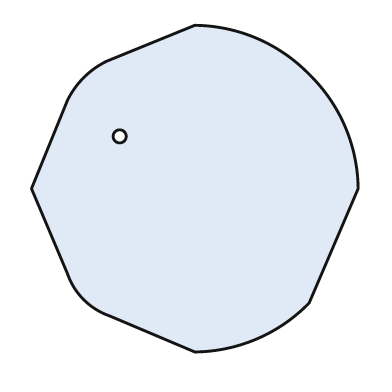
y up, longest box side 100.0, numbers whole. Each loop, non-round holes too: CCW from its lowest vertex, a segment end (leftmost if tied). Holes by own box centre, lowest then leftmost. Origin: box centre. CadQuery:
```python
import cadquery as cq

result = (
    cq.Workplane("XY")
    .moveTo(0.0, -50.0)
    .threePointArc((19.0, -46.0), (35.0, -35.0))
    .lineTo(50.0, 0.0)
    .threePointArc((46.0, 19.0), (35.0, 35.0))
    .threePointArc((19.0, 46.0), (0.0, 50.0))
    .lineTo(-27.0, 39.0)
    .threePointArc((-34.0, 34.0), (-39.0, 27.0))
    .lineTo(-50.0, 0.0)
    .lineTo(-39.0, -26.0)
    .threePointArc((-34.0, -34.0), (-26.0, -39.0))
    .close()
    .moveTo(-23.0, 16.0)
    .circle(2.0)
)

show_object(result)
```